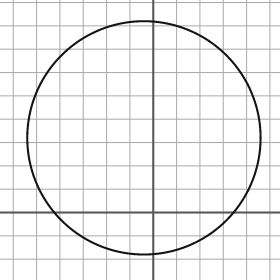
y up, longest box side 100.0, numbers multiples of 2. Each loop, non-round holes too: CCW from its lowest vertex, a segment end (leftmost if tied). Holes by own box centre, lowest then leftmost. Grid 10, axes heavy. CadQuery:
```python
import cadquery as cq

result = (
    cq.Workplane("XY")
    .moveTo(-4.0, 32.0)
    .circle(50.0)
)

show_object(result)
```